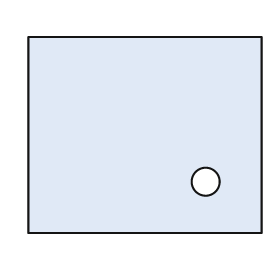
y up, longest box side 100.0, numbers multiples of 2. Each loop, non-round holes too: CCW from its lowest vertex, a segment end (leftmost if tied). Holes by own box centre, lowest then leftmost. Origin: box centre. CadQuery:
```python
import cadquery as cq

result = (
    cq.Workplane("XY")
    .moveTo(-50.0, -42.0)
    .lineTo(50.0, -42.0)
    .lineTo(50.0, 42.0)
    .lineTo(-50.0, 42.0)
    .close()
    .moveTo(26.0, -20.0)
    .circle(6.0)
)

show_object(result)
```